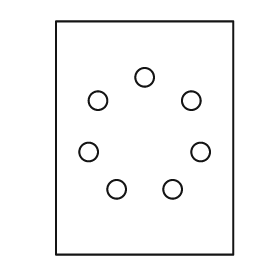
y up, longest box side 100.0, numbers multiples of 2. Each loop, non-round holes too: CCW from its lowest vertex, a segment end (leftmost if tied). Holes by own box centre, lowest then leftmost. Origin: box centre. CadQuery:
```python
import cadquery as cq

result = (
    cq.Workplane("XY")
    .moveTo(-38.0, -50.0)
    .lineTo(38.0, -50.0)
    .lineTo(38.0, 50.0)
    .lineTo(-38.0, 50.0)
    .close()
    .moveTo(-12.0, -22.0)
    .circle(4.0)
    .moveTo(12.0, -22.0)
    .circle(4.0)
    .moveTo(-24.0, -6.0)
    .circle(4.0)
    .moveTo(24.0, -6.0)
    .circle(4.0)
    .moveTo(-20.0, 16.0)
    .circle(4.0)
    .moveTo(20.0, 16.0)
    .circle(4.0)
    .moveTo(0.0, 26.0)
    .circle(4.0)
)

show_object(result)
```